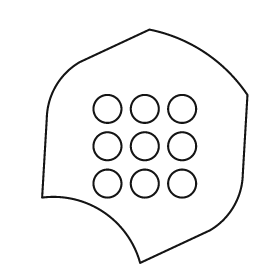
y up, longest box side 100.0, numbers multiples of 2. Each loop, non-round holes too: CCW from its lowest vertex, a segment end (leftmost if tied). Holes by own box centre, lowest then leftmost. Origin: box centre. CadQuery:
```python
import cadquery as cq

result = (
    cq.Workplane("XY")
    .moveTo(-2.0, -50.0)
    .lineTo(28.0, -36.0)
    .threePointArc((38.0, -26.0), (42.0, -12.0))
    .lineTo(44.0, 22.0)
    .threePointArc((26.0, 40.0), (2.0, 50.0))
    .lineTo(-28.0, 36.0)
    .threePointArc((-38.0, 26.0), (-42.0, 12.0))
    .lineTo(-44.0, -22.0)
    .threePointArc((-18.0, -28.0), (-2.0, -50.0))
    .close()
    .moveTo(-16.0, -16.0)
    .circle(6.0)
    .moveTo(0.0, -16.0)
    .circle(6.0)
    .moveTo(16.0, -16.0)
    .circle(6.0)
    .moveTo(-16.0, 0.0)
    .circle(6.0)
    .moveTo(0.0, 0.0)
    .circle(6.0)
    .moveTo(16.0, 0.0)
    .circle(6.0)
    .moveTo(-16.0, 16.0)
    .circle(6.0)
    .moveTo(0.0, 16.0)
    .circle(6.0)
    .moveTo(16.0, 16.0)
    .circle(6.0)
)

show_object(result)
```